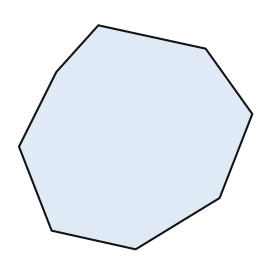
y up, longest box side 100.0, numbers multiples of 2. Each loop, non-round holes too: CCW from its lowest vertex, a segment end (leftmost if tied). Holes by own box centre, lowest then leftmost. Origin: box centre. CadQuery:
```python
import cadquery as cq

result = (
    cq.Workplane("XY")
    .moveTo(0.0, -48.0)
    .lineTo(36.0, -26.0)
    .lineTo(50.0, 10.0)
    .lineTo(30.0, 38.0)
    .lineTo(-16.0, 48.0)
    .lineTo(-34.0, 28.0)
    .lineTo(-50.0, -4.0)
    .lineTo(-36.0, -40.0)
    .close()
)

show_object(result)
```